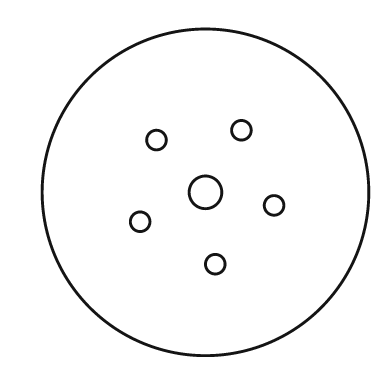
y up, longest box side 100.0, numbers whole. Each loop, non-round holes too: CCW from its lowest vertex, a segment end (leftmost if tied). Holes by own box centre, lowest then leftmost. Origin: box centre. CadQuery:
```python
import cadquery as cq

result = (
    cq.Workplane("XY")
    .moveTo(0.0, 0.0)
    .circle(50.0)
    .moveTo(3.0, -22.0)
    .circle(3.0)
    .moveTo(-20.0, -9.0)
    .circle(3.0)
    .moveTo(21.0, -4.0)
    .circle(3.0)
    .moveTo(0.0, 0.0)
    .circle(5.0)
    .moveTo(-15.0, 16.0)
    .circle(3.0)
    .moveTo(11.0, 19.0)
    .circle(3.0)
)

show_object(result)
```